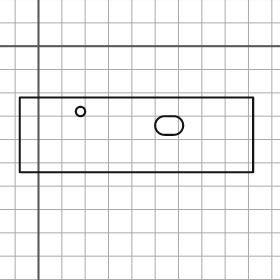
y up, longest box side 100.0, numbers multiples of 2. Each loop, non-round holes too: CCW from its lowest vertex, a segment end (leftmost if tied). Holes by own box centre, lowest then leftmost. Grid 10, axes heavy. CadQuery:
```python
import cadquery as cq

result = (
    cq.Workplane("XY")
    .moveTo(-8.0, -54.0)
    .lineTo(92.0, -54.0)
    .lineTo(92.0, -22.0)
    .lineTo(-8.0, -22.0)
    .close()
    .moveTo(54.0, -38.0)
    .lineTo(58.0, -38.0)
    .threePointArc((62.0, -34.0), (58.0, -30.0))
    .lineTo(54.0, -30.0)
    .threePointArc((50.0, -34.0), (54.0, -38.0))
    .close()
    .moveTo(18.0, -28.0)
    .circle(2.0)
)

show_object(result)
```